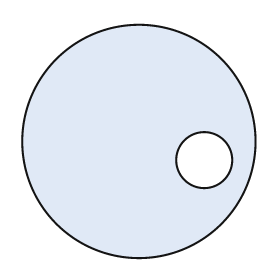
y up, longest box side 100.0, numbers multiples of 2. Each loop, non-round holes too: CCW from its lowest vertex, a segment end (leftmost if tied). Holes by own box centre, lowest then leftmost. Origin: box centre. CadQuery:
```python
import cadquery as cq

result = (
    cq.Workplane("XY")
    .moveTo(0.0, 0.0)
    .circle(50.0)
    .moveTo(28.0, -8.0)
    .circle(12.0)
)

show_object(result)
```